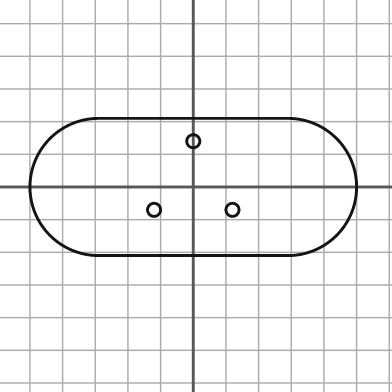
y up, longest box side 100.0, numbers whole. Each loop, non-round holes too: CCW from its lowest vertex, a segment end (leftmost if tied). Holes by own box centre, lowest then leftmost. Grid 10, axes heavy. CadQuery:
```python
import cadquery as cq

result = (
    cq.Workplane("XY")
    .moveTo(-29.0, -21.0)
    .lineTo(29.0, -21.0)
    .threePointArc((50.0, 0.0), (29.0, 21.0))
    .lineTo(-29.0, 21.0)
    .threePointArc((-50.0, 0.0), (-29.0, -21.0))
    .close()
    .moveTo(-12.0, -7.0)
    .circle(2.0)
    .moveTo(12.0, -7.0)
    .circle(2.0)
    .moveTo(0.0, 14.0)
    .circle(2.0)
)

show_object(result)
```